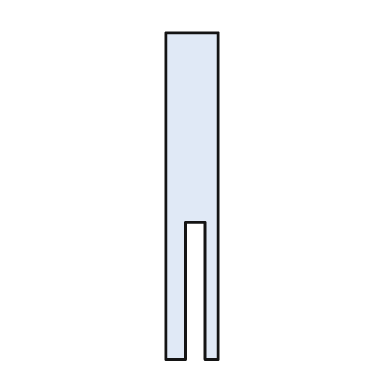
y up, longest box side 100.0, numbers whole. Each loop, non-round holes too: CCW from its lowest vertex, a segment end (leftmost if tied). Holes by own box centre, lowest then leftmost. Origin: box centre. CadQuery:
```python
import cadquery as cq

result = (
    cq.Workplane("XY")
    .moveTo(-8.0, -50.0)
    .lineTo(-2.0, -50.0)
    .lineTo(-2.0, -8.0)
    .lineTo(4.0, -8.0)
    .lineTo(4.0, -50.0)
    .lineTo(8.0, -50.0)
    .lineTo(8.0, 50.0)
    .lineTo(-8.0, 50.0)
    .close()
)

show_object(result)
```